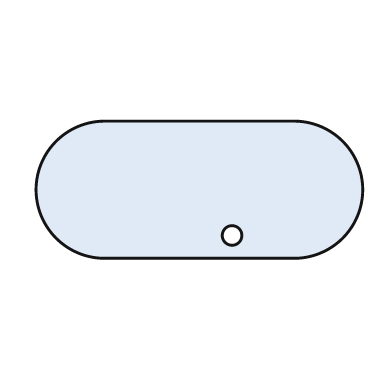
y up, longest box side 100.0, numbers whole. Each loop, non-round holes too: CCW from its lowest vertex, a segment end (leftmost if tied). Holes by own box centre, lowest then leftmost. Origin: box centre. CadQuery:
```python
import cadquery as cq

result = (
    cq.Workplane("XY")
    .moveTo(-29.0, -21.0)
    .lineTo(29.0, -21.0)
    .threePointArc((50.0, 0.0), (29.0, 21.0))
    .lineTo(-29.0, 21.0)
    .threePointArc((-50.0, 0.0), (-29.0, -21.0))
    .close()
    .moveTo(10.0, -14.0)
    .circle(3.0)
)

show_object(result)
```